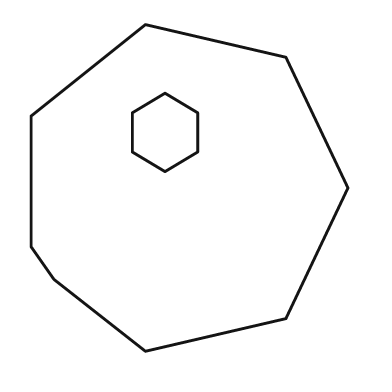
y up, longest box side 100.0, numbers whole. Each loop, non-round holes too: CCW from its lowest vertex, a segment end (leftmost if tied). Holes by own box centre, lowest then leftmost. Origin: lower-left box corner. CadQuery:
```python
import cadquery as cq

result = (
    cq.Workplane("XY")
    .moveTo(35.0, 0.0)
    .lineTo(78.0, 10.0)
    .lineTo(97.0, 50.0)
    .lineTo(78.0, 90.0)
    .lineTo(35.0, 100.0)
    .lineTo(0.0, 72.0)
    .lineTo(0.0, 32.0)
    .lineTo(7.0, 22.0)
    .close()
    .moveTo(41.0, 55.0)
    .lineTo(51.0, 61.0)
    .lineTo(51.0, 73.0)
    .lineTo(41.0, 79.0)
    .lineTo(31.0, 73.0)
    .lineTo(31.0, 61.0)
    .close()
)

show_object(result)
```